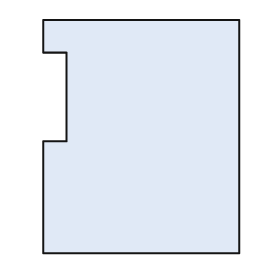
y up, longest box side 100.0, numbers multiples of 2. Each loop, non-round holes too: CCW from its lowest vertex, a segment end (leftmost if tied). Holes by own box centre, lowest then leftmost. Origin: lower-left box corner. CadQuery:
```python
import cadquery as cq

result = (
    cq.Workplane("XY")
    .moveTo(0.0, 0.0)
    .lineTo(84.0, 0.0)
    .lineTo(84.0, 100.0)
    .lineTo(0.0, 100.0)
    .lineTo(0.0, 86.0)
    .lineTo(10.0, 86.0)
    .lineTo(10.0, 48.0)
    .lineTo(0.0, 48.0)
    .close()
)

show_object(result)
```